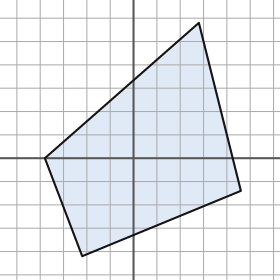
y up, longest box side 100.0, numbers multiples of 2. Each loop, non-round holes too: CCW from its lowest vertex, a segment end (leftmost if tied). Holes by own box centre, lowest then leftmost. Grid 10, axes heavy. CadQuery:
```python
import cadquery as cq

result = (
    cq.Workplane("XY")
    .moveTo(-22.0, -42.0)
    .lineTo(46.0, -14.0)
    .lineTo(28.0, 58.0)
    .lineTo(-38.0, 0.0)
    .close()
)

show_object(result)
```